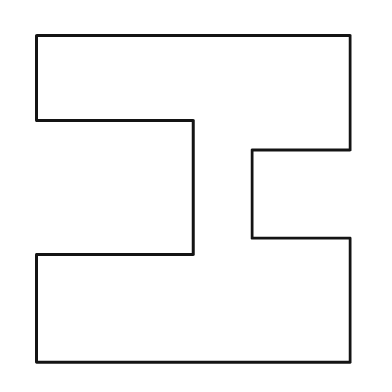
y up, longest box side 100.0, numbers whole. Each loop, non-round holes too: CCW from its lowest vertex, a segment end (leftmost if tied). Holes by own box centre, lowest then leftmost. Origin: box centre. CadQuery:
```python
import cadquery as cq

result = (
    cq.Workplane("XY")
    .moveTo(-48.0, -50.0)
    .lineTo(48.0, -50.0)
    .lineTo(48.0, -12.0)
    .lineTo(18.0, -12.0)
    .lineTo(18.0, 15.0)
    .lineTo(48.0, 15.0)
    .lineTo(48.0, 50.0)
    .lineTo(-48.0, 50.0)
    .lineTo(-48.0, 24.0)
    .lineTo(0.0, 24.0)
    .lineTo(0.0, -17.0)
    .lineTo(-48.0, -17.0)
    .close()
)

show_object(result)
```